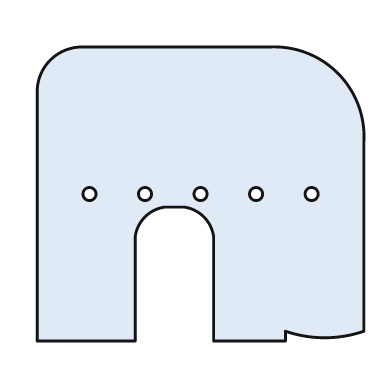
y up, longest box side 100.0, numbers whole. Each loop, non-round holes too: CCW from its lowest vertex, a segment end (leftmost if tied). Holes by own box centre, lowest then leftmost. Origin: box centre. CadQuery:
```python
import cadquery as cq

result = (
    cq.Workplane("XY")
    .moveTo(-50.0, -45.0)
    .lineTo(-20.0, -45.0)
    .lineTo(-20.0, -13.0)
    .threePointArc((-17.0, -7.0), (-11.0, -4.0))
    .lineTo(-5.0, -4.0)
    .threePointArc((1.0, -7.0), (4.0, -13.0))
    .lineTo(4.0, -45.0)
    .lineTo(26.0, -45.0)
    .lineTo(26.0, -42.0)
    .threePointArc((38.0, -44.0), (50.0, -42.0))
    .lineTo(50.0, 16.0)
    .threePointArc((42.0, 37.0), (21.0, 45.0))
    .lineTo(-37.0, 45.0)
    .threePointArc((-46.0, 41.0), (-50.0, 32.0))
    .close()
    .moveTo(-34.0, 0.0)
    .circle(2.0)
    .moveTo(-17.0, 0.0)
    .circle(2.0)
    .moveTo(0.0, 0.0)
    .circle(2.0)
    .moveTo(17.0, 0.0)
    .circle(2.0)
    .moveTo(34.0, 0.0)
    .circle(2.0)
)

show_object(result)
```